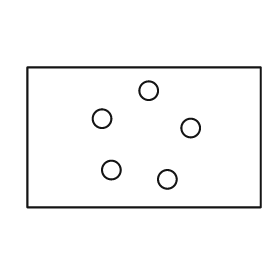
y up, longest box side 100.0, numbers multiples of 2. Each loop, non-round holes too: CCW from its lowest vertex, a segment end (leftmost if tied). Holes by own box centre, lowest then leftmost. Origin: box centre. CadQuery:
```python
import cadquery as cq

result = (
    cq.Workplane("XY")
    .moveTo(-50.0, -30.0)
    .lineTo(50.0, -30.0)
    .lineTo(50.0, 30.0)
    .lineTo(-50.0, 30.0)
    .close()
    .moveTo(10.0, -18.0)
    .circle(4.0)
    .moveTo(-14.0, -14.0)
    .circle(4.0)
    .moveTo(20.0, 4.0)
    .circle(4.0)
    .moveTo(-18.0, 8.0)
    .circle(4.0)
    .moveTo(2.0, 20.0)
    .circle(4.0)
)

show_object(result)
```